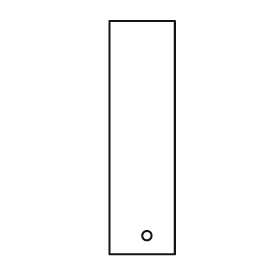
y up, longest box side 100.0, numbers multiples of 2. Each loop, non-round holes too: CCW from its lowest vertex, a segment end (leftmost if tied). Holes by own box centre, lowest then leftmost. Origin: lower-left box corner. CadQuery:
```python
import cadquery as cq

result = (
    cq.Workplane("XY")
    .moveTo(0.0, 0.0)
    .lineTo(28.0, 0.0)
    .lineTo(28.0, 100.0)
    .lineTo(0.0, 100.0)
    .close()
    .moveTo(16.0, 8.0)
    .circle(2.0)
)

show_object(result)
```